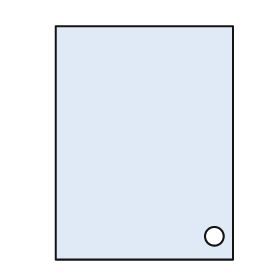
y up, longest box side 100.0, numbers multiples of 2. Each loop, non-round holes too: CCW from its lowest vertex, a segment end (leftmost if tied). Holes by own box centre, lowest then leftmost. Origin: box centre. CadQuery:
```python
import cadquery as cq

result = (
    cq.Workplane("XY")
    .moveTo(-38.0, -50.0)
    .lineTo(38.0, -50.0)
    .lineTo(38.0, 50.0)
    .lineTo(-38.0, 50.0)
    .close()
    .moveTo(30.0, -40.0)
    .circle(4.0)
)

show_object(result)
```